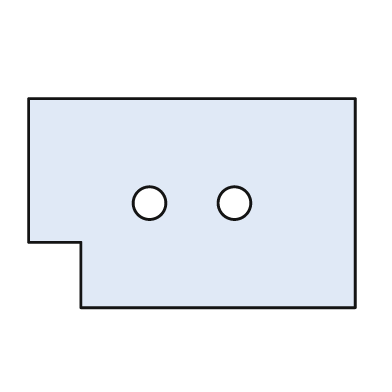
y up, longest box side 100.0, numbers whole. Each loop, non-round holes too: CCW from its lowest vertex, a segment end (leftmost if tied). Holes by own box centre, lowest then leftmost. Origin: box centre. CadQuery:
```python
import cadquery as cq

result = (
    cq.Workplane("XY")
    .moveTo(-34.0, -32.0)
    .lineTo(50.0, -32.0)
    .lineTo(50.0, 32.0)
    .lineTo(-50.0, 32.0)
    .lineTo(-50.0, -12.0)
    .lineTo(-34.0, -12.0)
    .close()
    .moveTo(-13.0, 0.0)
    .circle(5.0)
    .moveTo(13.0, 0.0)
    .circle(5.0)
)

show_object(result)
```